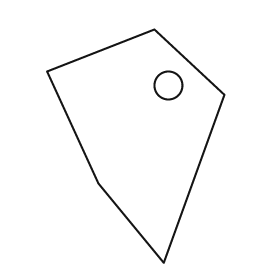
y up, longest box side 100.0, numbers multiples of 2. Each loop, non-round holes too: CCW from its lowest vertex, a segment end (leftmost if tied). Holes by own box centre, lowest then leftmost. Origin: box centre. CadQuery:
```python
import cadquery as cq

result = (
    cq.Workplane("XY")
    .moveTo(12.0, -50.0)
    .lineTo(38.0, 22.0)
    .lineTo(8.0, 50.0)
    .lineTo(-38.0, 32.0)
    .lineTo(-16.0, -16.0)
    .close()
    .moveTo(14.0, 26.0)
    .circle(6.0)
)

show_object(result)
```